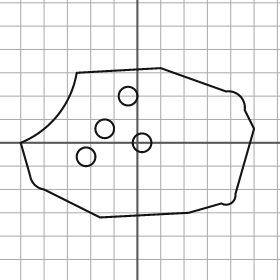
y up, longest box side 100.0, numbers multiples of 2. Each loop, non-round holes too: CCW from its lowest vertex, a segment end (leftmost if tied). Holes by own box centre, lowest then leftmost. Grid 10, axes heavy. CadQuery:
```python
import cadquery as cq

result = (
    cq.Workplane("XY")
    .moveTo(-16.0, -32.0)
    .lineTo(22.0, -30.0)
    .lineTo(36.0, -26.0)
    .threePointArc((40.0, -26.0), (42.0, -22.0))
    .lineTo(50.0, 6.0)
    .lineTo(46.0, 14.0)
    .threePointArc((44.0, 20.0), (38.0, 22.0))
    .lineTo(10.0, 32.0)
    .lineTo(-26.0, 30.0)
    .threePointArc((-34.0, 12.0), (-50.0, 0.0))
    .lineTo(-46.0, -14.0)
    .threePointArc((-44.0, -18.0), (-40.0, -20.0))
    .close()
    .moveTo(-22.0, -6.0)
    .circle(4.0)
    .moveTo(2.0, 0.0)
    .circle(4.0)
    .moveTo(-14.0, 6.0)
    .circle(4.0)
    .moveTo(-4.0, 20.0)
    .circle(4.0)
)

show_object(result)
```